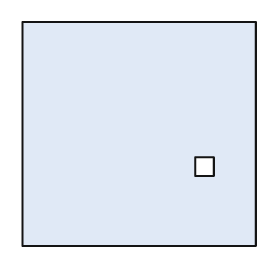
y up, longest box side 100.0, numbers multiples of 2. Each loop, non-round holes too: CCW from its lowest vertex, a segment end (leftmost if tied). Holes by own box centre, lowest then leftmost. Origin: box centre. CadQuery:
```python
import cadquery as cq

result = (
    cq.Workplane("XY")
    .moveTo(-50.0, -48.0)
    .lineTo(50.0, -48.0)
    .lineTo(50.0, 48.0)
    .lineTo(-50.0, 48.0)
    .close()
    .moveTo(24.0, -18.0)
    .lineTo(32.0, -18.0)
    .lineTo(32.0, -10.0)
    .lineTo(24.0, -10.0)
    .close()
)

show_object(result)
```